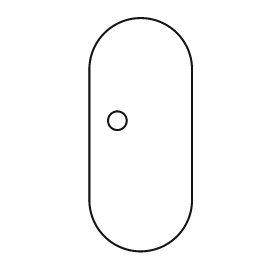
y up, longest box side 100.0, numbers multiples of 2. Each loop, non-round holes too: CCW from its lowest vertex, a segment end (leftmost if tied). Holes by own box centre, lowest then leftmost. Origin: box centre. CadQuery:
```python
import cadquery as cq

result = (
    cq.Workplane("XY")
    .moveTo(-22.0, -28.0)
    .threePointArc((0.0, -50.0), (22.0, -28.0))
    .lineTo(22.0, 28.0)
    .threePointArc((0.0, 50.0), (-22.0, 28.0))
    .close()
    .moveTo(-10.0, 6.0)
    .circle(4.0)
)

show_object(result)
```